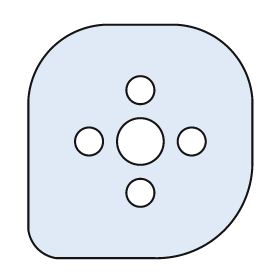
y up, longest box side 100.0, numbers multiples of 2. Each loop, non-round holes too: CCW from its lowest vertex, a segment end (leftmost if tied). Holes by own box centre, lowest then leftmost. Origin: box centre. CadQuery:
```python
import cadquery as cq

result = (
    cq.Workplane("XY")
    .moveTo(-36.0, -50.0)
    .lineTo(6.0, -50.0)
    .threePointArc((36.0, -38.0), (48.0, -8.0))
    .lineTo(48.0, 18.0)
    .threePointArc((38.0, 40.0), (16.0, 50.0))
    .lineTo(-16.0, 50.0)
    .threePointArc((-38.0, 40.0), (-48.0, 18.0))
    .lineTo(-48.0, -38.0)
    .threePointArc((-44.0, -46.0), (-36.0, -50.0))
    .close()
    .moveTo(0.0, -22.0)
    .circle(6.0)
    .moveTo(-22.0, 0.0)
    .circle(6.0)
    .moveTo(0.0, 0.0)
    .circle(10.0)
    .moveTo(22.0, 0.0)
    .circle(6.0)
    .moveTo(0.0, 22.0)
    .circle(6.0)
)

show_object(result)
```